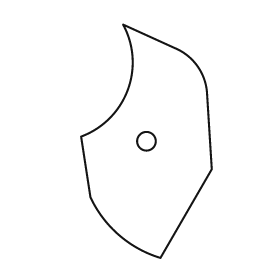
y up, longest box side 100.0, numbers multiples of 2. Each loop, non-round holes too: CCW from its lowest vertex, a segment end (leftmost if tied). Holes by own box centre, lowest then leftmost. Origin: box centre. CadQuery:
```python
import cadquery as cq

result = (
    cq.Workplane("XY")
    .moveTo(6.0, -50.0)
    .lineTo(28.0, -12.0)
    .lineTo(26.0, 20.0)
    .threePointArc((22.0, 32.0), (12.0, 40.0))
    .lineTo(-10.0, 50.0)
    .threePointArc((-8.0, 22.0), (-28.0, 2.0))
    .lineTo(-24.0, -24.0)
    .threePointArc((-12.0, -40.0), (6.0, -50.0))
    .close()
    .moveTo(0.0, 0.0)
    .circle(4.0)
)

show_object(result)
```